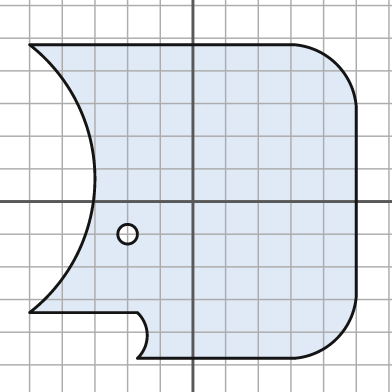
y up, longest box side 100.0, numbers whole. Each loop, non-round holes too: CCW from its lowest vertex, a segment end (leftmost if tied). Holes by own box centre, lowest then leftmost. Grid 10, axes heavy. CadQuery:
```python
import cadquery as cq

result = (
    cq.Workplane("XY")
    .moveTo(-17.0, -48.0)
    .lineTo(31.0, -48.0)
    .threePointArc((44.0, -42.0), (50.0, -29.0))
    .lineTo(50.0, 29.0)
    .threePointArc((44.0, 42.0), (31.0, 48.0))
    .lineTo(-50.0, 48.0)
    .threePointArc((-30.0, 7.0), (-50.0, -34.0))
    .lineTo(-17.0, -34.0)
    .threePointArc((-14.0, -41.0), (-17.0, -48.0))
    .close()
    .moveTo(-20.0, -10.0)
    .circle(3.0)
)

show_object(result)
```